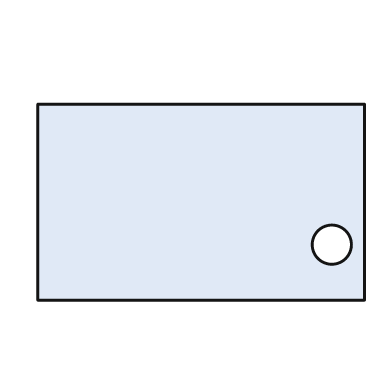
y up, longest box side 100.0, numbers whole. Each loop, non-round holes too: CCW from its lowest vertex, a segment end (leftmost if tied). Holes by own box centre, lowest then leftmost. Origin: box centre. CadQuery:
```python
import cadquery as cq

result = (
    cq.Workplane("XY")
    .moveTo(-50.0, -30.0)
    .lineTo(50.0, -30.0)
    .lineTo(50.0, 30.0)
    .lineTo(-50.0, 30.0)
    .close()
    .moveTo(40.0, -13.0)
    .circle(6.0)
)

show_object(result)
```